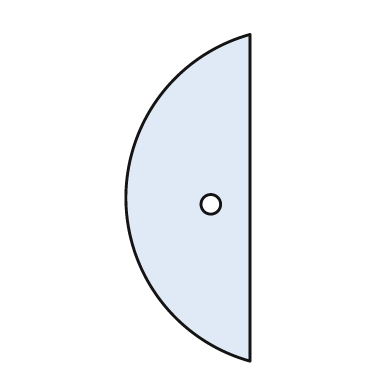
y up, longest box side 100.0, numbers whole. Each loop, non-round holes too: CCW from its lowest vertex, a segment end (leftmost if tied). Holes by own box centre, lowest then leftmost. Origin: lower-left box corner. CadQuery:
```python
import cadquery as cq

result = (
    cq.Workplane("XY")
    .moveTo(38.0, 0.0)
    .lineTo(38.0, 100.0)
    .threePointArc((0.0, 50.0), (38.0, 0.0))
    .close()
    .moveTo(26.0, 48.0)
    .circle(3.0)
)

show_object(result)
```